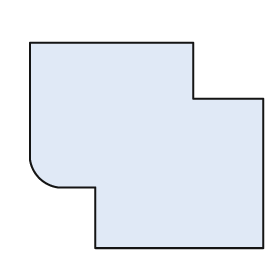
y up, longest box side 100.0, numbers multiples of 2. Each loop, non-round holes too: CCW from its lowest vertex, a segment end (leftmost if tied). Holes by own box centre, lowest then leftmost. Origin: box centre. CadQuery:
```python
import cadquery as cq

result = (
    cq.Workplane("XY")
    .moveTo(-22.0, -44.0)
    .lineTo(50.0, -44.0)
    .lineTo(50.0, 20.0)
    .lineTo(20.0, 20.0)
    .lineTo(20.0, 44.0)
    .lineTo(-50.0, 44.0)
    .lineTo(-50.0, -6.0)
    .threePointArc((-46.0, -14.0), (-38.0, -18.0))
    .lineTo(-22.0, -18.0)
    .close()
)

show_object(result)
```